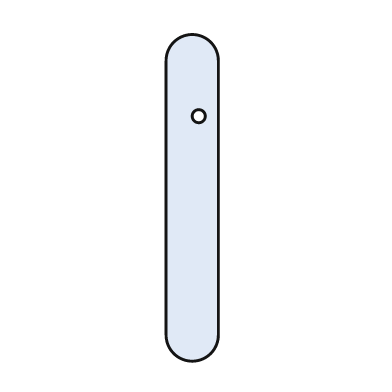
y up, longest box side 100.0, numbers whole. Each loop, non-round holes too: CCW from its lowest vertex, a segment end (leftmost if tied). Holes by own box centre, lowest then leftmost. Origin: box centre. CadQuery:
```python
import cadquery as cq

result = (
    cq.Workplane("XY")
    .moveTo(-8.0, -42.0)
    .threePointArc((0.0, -50.0), (8.0, -42.0))
    .lineTo(8.0, 42.0)
    .threePointArc((0.0, 50.0), (-8.0, 42.0))
    .close()
    .moveTo(2.0, 25.0)
    .circle(2.0)
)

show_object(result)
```